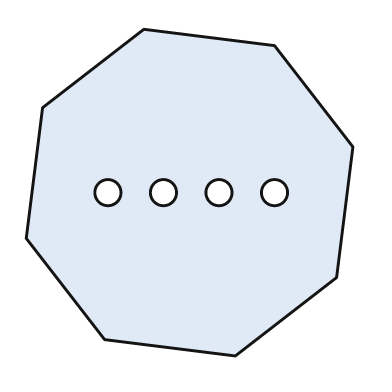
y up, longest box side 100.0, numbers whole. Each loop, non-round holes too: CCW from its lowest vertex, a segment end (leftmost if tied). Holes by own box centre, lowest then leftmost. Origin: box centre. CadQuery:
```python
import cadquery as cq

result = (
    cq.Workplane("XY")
    .moveTo(14.0, -50.0)
    .lineTo(45.0, -26.0)
    .lineTo(50.0, 14.0)
    .lineTo(26.0, 45.0)
    .lineTo(-14.0, 50.0)
    .lineTo(-45.0, 26.0)
    .lineTo(-50.0, -14.0)
    .lineTo(-26.0, -45.0)
    .close()
    .moveTo(-25.0, 0.0)
    .circle(4.0)
    .moveTo(-8.0, 0.0)
    .circle(4.0)
    .moveTo(9.0, 0.0)
    .circle(4.0)
    .moveTo(26.0, 0.0)
    .circle(4.0)
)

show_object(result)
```